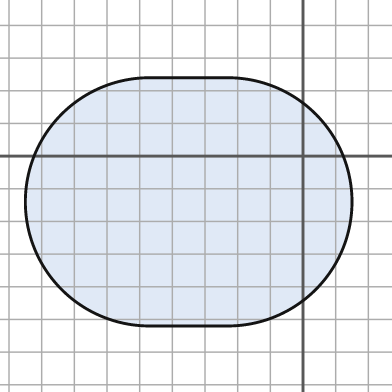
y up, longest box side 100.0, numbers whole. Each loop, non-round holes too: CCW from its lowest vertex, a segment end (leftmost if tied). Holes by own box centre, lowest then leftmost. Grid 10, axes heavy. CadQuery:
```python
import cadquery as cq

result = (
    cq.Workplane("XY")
    .moveTo(-47.0, -52.0)
    .lineTo(-23.0, -52.0)
    .threePointArc((15.0, -14.0), (-23.0, 24.0))
    .lineTo(-47.0, 24.0)
    .threePointArc((-85.0, -14.0), (-47.0, -52.0))
    .close()
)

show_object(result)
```